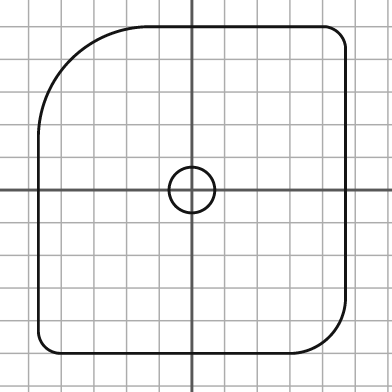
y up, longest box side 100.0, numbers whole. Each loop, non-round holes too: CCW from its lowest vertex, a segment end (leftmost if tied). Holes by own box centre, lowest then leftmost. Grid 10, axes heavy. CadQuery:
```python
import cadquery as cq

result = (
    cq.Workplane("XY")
    .moveTo(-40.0, -50.0)
    .lineTo(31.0, -50.0)
    .threePointArc((42.0, -45.0), (47.0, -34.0))
    .lineTo(47.0, 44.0)
    .threePointArc((45.0, 48.0), (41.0, 50.0))
    .lineTo(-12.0, 50.0)
    .threePointArc((-37.0, 40.0), (-47.0, 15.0))
    .lineTo(-47.0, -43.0)
    .threePointArc((-45.0, -48.0), (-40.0, -50.0))
    .close()
    .moveTo(0.0, 0.0)
    .circle(7.0)
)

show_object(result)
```